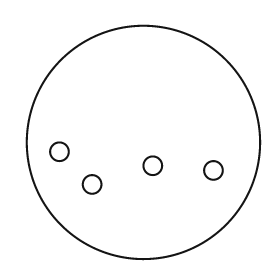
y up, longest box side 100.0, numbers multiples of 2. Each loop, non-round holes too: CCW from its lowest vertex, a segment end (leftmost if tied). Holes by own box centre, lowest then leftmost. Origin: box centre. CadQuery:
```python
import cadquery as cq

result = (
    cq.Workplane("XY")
    .moveTo(0.0, 0.0)
    .circle(50.0)
    .moveTo(-22.0, -18.0)
    .circle(4.0)
    .moveTo(30.0, -12.0)
    .circle(4.0)
    .moveTo(4.0, -10.0)
    .circle(4.0)
    .moveTo(-36.0, -4.0)
    .circle(4.0)
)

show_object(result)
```